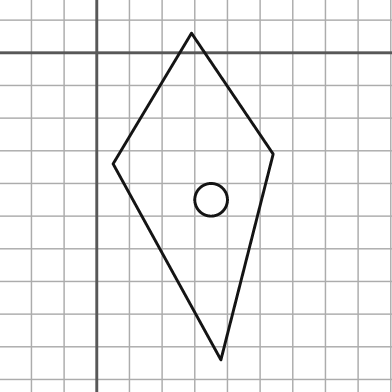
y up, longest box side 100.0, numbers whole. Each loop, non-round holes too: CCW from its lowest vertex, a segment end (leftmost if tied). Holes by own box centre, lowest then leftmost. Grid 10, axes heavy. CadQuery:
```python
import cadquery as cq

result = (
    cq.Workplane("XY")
    .moveTo(38.0, -94.0)
    .lineTo(54.0, -31.0)
    .lineTo(29.0, 6.0)
    .lineTo(5.0, -34.0)
    .close()
    .moveTo(35.0, -45.0)
    .circle(5.0)
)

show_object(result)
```